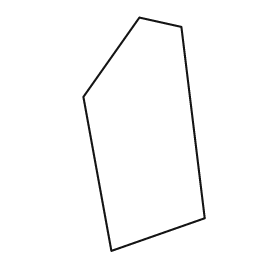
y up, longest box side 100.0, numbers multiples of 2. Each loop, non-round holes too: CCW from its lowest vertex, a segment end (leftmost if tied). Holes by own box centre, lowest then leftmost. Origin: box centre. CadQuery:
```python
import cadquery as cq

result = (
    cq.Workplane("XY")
    .moveTo(-14.0, -50.0)
    .lineTo(26.0, -36.0)
    .lineTo(16.0, 46.0)
    .lineTo(-2.0, 50.0)
    .lineTo(-26.0, 16.0)
    .close()
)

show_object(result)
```